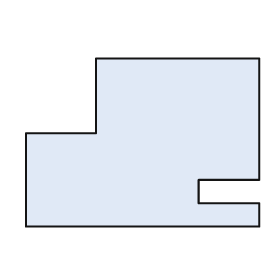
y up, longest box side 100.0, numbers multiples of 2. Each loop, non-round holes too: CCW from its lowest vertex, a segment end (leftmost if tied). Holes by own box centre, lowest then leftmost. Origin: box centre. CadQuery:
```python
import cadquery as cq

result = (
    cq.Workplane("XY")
    .moveTo(-50.0, -36.0)
    .lineTo(50.0, -36.0)
    .lineTo(50.0, -26.0)
    .lineTo(24.0, -26.0)
    .lineTo(24.0, -16.0)
    .lineTo(50.0, -16.0)
    .lineTo(50.0, 36.0)
    .lineTo(-20.0, 36.0)
    .lineTo(-20.0, 4.0)
    .lineTo(-50.0, 4.0)
    .close()
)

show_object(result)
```